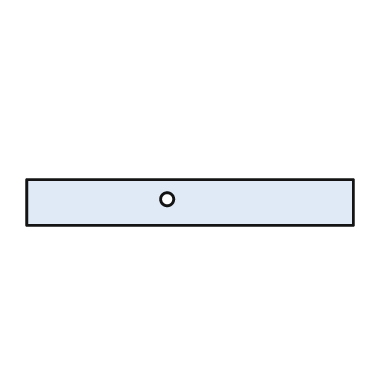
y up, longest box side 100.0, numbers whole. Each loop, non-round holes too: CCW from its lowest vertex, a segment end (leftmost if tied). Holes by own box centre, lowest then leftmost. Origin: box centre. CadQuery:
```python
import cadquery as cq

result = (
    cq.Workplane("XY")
    .moveTo(-50.0, -7.0)
    .lineTo(50.0, -7.0)
    .lineTo(50.0, 7.0)
    .lineTo(-50.0, 7.0)
    .close()
    .moveTo(-7.0, 1.0)
    .circle(2.0)
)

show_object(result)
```